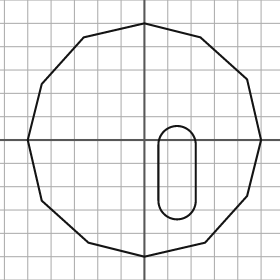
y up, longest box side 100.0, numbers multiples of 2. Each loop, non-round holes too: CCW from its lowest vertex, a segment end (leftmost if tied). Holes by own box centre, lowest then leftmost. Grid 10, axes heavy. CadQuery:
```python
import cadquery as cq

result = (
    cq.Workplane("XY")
    .moveTo(0.0, -50.0)
    .lineTo(26.0, -44.0)
    .lineTo(44.0, -24.0)
    .lineTo(50.0, 0.0)
    .lineTo(44.0, 26.0)
    .lineTo(24.0, 44.0)
    .lineTo(0.0, 50.0)
    .lineTo(-26.0, 44.0)
    .lineTo(-44.0, 24.0)
    .lineTo(-50.0, 0.0)
    .lineTo(-44.0, -26.0)
    .lineTo(-24.0, -44.0)
    .close()
    .moveTo(6.0, -26.0)
    .threePointArc((14.0, -34.0), (22.0, -26.0))
    .lineTo(22.0, -2.0)
    .threePointArc((14.0, 6.0), (6.0, -2.0))
    .close()
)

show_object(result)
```